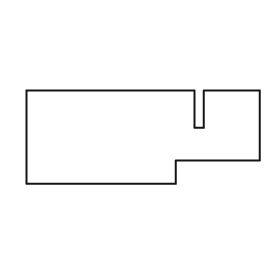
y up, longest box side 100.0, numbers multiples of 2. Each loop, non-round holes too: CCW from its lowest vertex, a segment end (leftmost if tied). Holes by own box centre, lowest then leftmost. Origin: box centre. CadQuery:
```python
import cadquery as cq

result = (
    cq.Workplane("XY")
    .moveTo(-50.0, -20.0)
    .lineTo(14.0, -20.0)
    .lineTo(14.0, -10.0)
    .lineTo(50.0, -10.0)
    .lineTo(50.0, 20.0)
    .lineTo(26.0, 20.0)
    .lineTo(26.0, 4.0)
    .lineTo(22.0, 4.0)
    .lineTo(22.0, 20.0)
    .lineTo(-50.0, 20.0)
    .close()
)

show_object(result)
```